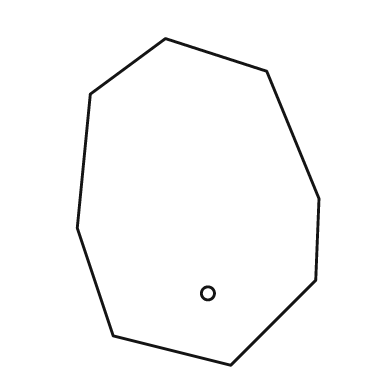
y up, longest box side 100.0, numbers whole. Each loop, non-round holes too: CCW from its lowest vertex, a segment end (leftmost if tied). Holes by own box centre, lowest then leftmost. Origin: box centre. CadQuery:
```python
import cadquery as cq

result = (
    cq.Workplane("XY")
    .moveTo(10.0, -50.0)
    .lineTo(36.0, -24.0)
    .lineTo(37.0, 1.0)
    .lineTo(21.0, 40.0)
    .lineTo(-10.0, 50.0)
    .lineTo(-33.0, 33.0)
    .lineTo(-37.0, -8.0)
    .lineTo(-26.0, -41.0)
    .close()
    .moveTo(3.0, -28.0)
    .circle(2.0)
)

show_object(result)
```